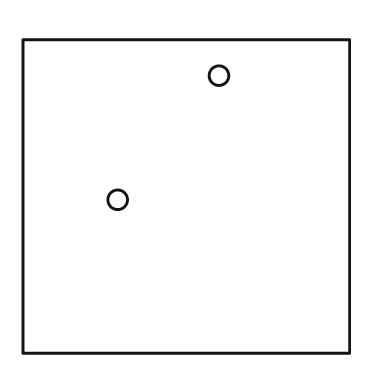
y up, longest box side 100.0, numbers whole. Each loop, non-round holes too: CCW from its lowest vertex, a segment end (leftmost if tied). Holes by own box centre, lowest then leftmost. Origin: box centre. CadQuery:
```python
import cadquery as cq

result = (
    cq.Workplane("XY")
    .moveTo(-50.0, -48.0)
    .lineTo(50.0, -48.0)
    .lineTo(50.0, 48.0)
    .lineTo(-50.0, 48.0)
    .close()
    .moveTo(-21.0, -1.0)
    .circle(3.0)
    .moveTo(10.0, 37.0)
    .circle(3.0)
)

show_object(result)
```